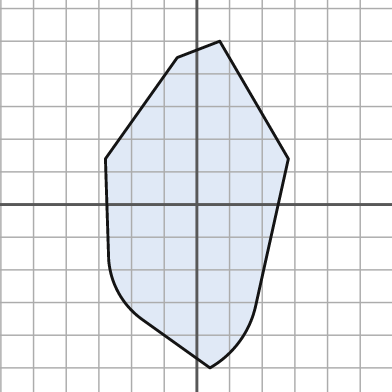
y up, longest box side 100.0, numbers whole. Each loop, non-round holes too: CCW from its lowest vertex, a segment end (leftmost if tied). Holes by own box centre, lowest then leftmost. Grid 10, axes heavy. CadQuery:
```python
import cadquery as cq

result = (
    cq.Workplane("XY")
    .moveTo(4.0, -50.0)
    .threePointArc((13.0, -42.0), (18.0, -31.0))
    .lineTo(28.0, 14.0)
    .lineTo(7.0, 50.0)
    .lineTo(-6.0, 45.0)
    .lineTo(-28.0, 14.0)
    .lineTo(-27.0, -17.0)
    .threePointArc((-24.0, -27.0), (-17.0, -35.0))
    .close()
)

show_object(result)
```